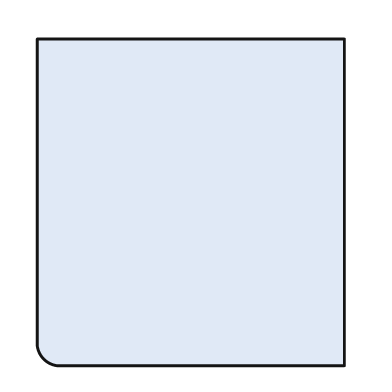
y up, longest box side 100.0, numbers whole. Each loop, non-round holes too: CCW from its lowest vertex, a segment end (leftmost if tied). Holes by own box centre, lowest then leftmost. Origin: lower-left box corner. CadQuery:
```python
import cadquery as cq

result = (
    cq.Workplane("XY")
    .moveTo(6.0, 0.0)
    .lineTo(94.0, 0.0)
    .lineTo(94.0, 100.0)
    .lineTo(0.0, 100.0)
    .lineTo(0.0, 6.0)
    .threePointArc((2.0, 2.0), (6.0, 0.0))
    .close()
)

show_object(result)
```